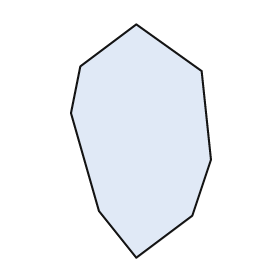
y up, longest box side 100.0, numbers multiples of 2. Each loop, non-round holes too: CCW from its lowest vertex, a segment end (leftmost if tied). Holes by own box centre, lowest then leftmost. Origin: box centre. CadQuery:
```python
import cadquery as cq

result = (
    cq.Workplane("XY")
    .moveTo(-2.0, -50.0)
    .lineTo(22.0, -32.0)
    .lineTo(30.0, -8.0)
    .lineTo(26.0, 30.0)
    .lineTo(-2.0, 50.0)
    .lineTo(-26.0, 32.0)
    .lineTo(-30.0, 12.0)
    .lineTo(-18.0, -30.0)
    .close()
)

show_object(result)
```